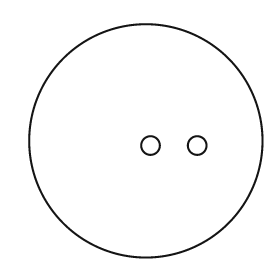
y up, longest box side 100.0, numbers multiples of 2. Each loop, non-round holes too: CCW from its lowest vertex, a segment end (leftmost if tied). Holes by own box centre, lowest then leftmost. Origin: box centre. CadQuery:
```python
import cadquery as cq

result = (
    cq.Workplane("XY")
    .moveTo(0.0, 0.0)
    .circle(50.0)
    .moveTo(2.0, -2.0)
    .circle(4.0)
    .moveTo(22.0, -2.0)
    .circle(4.0)
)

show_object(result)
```